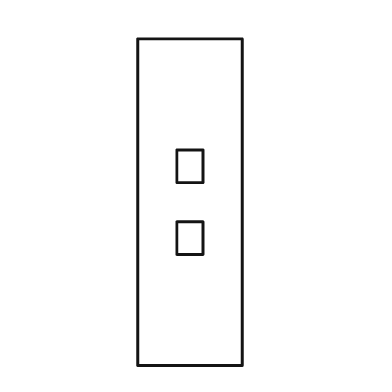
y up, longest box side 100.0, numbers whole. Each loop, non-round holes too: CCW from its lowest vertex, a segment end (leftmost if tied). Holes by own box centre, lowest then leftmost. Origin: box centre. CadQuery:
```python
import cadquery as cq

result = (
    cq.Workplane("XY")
    .moveTo(-16.0, -50.0)
    .lineTo(16.0, -50.0)
    .lineTo(16.0, 50.0)
    .lineTo(-16.0, 50.0)
    .close()
    .moveTo(-4.0, -16.0)
    .lineTo(4.0, -16.0)
    .lineTo(4.0, -6.0)
    .lineTo(-4.0, -6.0)
    .close()
    .moveTo(-4.0, 6.0)
    .lineTo(4.0, 6.0)
    .lineTo(4.0, 16.0)
    .lineTo(-4.0, 16.0)
    .close()
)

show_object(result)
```